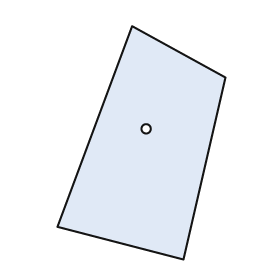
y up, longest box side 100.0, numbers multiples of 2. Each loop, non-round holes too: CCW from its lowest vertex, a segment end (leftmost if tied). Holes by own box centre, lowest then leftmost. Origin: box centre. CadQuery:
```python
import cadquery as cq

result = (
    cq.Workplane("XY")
    .moveTo(18.0, -50.0)
    .lineTo(36.0, 28.0)
    .lineTo(-4.0, 50.0)
    .lineTo(-36.0, -36.0)
    .close()
    .moveTo(2.0, 6.0)
    .circle(2.0)
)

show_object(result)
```